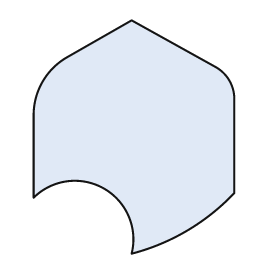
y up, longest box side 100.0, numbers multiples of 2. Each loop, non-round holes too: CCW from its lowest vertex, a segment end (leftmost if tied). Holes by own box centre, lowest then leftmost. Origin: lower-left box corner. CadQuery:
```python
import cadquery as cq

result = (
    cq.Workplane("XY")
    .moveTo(42.0, 0.0)
    .threePointArc((66.0, 10.0), (86.0, 26.0))
    .lineTo(86.0, 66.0)
    .threePointArc((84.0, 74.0), (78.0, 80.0))
    .lineTo(42.0, 100.0)
    .lineTo(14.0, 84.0)
    .threePointArc((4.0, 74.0), (0.0, 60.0))
    .lineTo(0.0, 24.0)
    .threePointArc((30.0, 28.0), (42.0, 0.0))
    .close()
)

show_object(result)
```